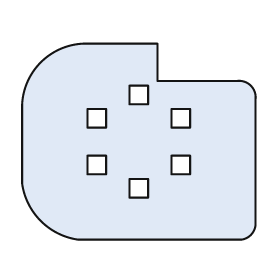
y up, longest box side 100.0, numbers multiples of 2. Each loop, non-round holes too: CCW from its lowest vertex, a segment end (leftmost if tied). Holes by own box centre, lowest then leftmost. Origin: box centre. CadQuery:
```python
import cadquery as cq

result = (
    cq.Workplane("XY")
    .moveTo(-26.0, -42.0)
    .lineTo(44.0, -42.0)
    .threePointArc((48.0, -40.0), (50.0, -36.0))
    .lineTo(50.0, 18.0)
    .threePointArc((48.0, 24.0), (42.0, 26.0))
    .lineTo(8.0, 26.0)
    .lineTo(8.0, 42.0)
    .lineTo(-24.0, 42.0)
    .threePointArc((-42.0, 34.0), (-50.0, 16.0))
    .lineTo(-50.0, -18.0)
    .threePointArc((-42.0, -34.0), (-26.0, -42.0))
    .close()
    .moveTo(-4.0, -24.0)
    .lineTo(4.0, -24.0)
    .lineTo(4.0, -16.0)
    .lineTo(-4.0, -16.0)
    .close()
    .moveTo(-22.0, -14.0)
    .lineTo(-14.0, -14.0)
    .lineTo(-14.0, -6.0)
    .lineTo(-22.0, -6.0)
    .close()
    .moveTo(14.0, -14.0)
    .lineTo(22.0, -14.0)
    .lineTo(22.0, -6.0)
    .lineTo(14.0, -6.0)
    .close()
    .moveTo(-22.0, 6.0)
    .lineTo(-14.0, 6.0)
    .lineTo(-14.0, 14.0)
    .lineTo(-22.0, 14.0)
    .close()
    .moveTo(14.0, 6.0)
    .lineTo(22.0, 6.0)
    .lineTo(22.0, 14.0)
    .lineTo(14.0, 14.0)
    .close()
    .moveTo(-4.0, 16.0)
    .lineTo(4.0, 16.0)
    .lineTo(4.0, 24.0)
    .lineTo(-4.0, 24.0)
    .close()
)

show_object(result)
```